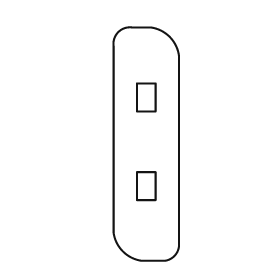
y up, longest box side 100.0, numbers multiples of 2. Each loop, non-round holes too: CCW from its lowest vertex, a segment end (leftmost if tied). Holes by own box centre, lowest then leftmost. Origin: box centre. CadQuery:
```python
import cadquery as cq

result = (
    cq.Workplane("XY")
    .moveTo(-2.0, -50.0)
    .lineTo(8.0, -50.0)
    .threePointArc((12.0, -48.0), (14.0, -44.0))
    .lineTo(14.0, 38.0)
    .threePointArc((10.0, 46.0), (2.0, 50.0))
    .lineTo(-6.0, 50.0)
    .threePointArc((-12.0, 48.0), (-14.0, 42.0))
    .lineTo(-14.0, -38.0)
    .threePointArc((-10.0, -46.0), (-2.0, -50.0))
    .close()
    .moveTo(-4.0, -24.0)
    .lineTo(4.0, -24.0)
    .lineTo(4.0, -12.0)
    .lineTo(-4.0, -12.0)
    .close()
    .moveTo(-4.0, 14.0)
    .lineTo(4.0, 14.0)
    .lineTo(4.0, 26.0)
    .lineTo(-4.0, 26.0)
    .close()
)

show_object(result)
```